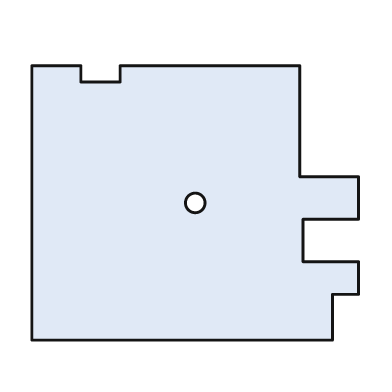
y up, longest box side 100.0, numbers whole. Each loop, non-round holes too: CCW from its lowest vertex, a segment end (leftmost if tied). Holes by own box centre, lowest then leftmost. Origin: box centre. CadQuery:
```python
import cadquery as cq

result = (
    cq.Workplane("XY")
    .moveTo(-50.0, -42.0)
    .lineTo(42.0, -42.0)
    .lineTo(42.0, -28.0)
    .lineTo(50.0, -28.0)
    .lineTo(50.0, -18.0)
    .lineTo(33.0, -18.0)
    .lineTo(33.0, -5.0)
    .lineTo(50.0, -5.0)
    .lineTo(50.0, 8.0)
    .lineTo(32.0, 8.0)
    .lineTo(32.0, 42.0)
    .lineTo(-23.0, 42.0)
    .lineTo(-23.0, 37.0)
    .lineTo(-35.0, 37.0)
    .lineTo(-35.0, 42.0)
    .lineTo(-50.0, 42.0)
    .close()
    .moveTo(0.0, 0.0)
    .circle(3.0)
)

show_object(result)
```